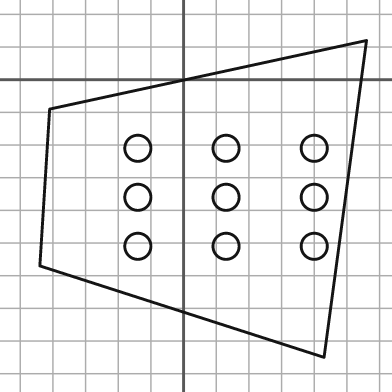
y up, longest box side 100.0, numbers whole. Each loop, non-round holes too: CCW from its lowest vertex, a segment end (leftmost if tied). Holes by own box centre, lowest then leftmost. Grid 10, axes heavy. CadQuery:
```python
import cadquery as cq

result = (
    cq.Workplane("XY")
    .moveTo(43.0, -85.0)
    .lineTo(56.0, 12.0)
    .lineTo(-41.0, -9.0)
    .lineTo(-44.0, -57.0)
    .close()
    .moveTo(-14.0, -51.0)
    .circle(4.0)
    .moveTo(13.0, -51.0)
    .circle(4.0)
    .moveTo(40.0, -51.0)
    .circle(4.0)
    .moveTo(-14.0, -36.0)
    .circle(4.0)
    .moveTo(13.0, -36.0)
    .circle(4.0)
    .moveTo(40.0, -36.0)
    .circle(4.0)
    .moveTo(-14.0, -21.0)
    .circle(4.0)
    .moveTo(13.0, -21.0)
    .circle(4.0)
    .moveTo(40.0, -21.0)
    .circle(4.0)
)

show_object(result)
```